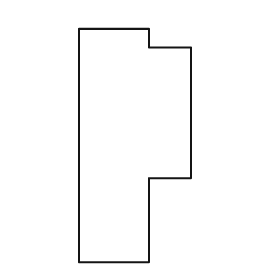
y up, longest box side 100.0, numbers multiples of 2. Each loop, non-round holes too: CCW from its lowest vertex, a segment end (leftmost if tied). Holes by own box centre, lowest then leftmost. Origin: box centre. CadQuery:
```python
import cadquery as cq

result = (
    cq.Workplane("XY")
    .moveTo(-24.0, -50.0)
    .lineTo(6.0, -50.0)
    .lineTo(6.0, -14.0)
    .lineTo(24.0, -14.0)
    .lineTo(24.0, 42.0)
    .lineTo(6.0, 42.0)
    .lineTo(6.0, 50.0)
    .lineTo(-24.0, 50.0)
    .close()
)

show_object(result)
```